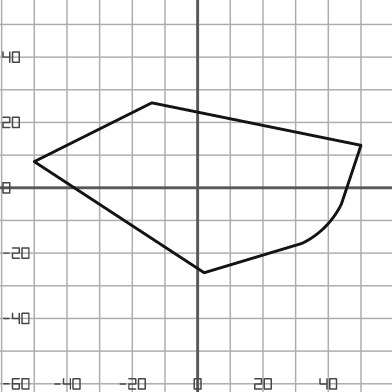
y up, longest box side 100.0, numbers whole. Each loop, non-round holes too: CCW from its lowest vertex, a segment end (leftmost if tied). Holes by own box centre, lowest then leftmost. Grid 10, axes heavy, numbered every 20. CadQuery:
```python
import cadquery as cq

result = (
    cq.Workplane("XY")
    .moveTo(2.0, -26.0)
    .lineTo(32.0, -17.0)
    .threePointArc((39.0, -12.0), (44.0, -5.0))
    .lineTo(50.0, 13.0)
    .lineTo(-14.0, 26.0)
    .lineTo(-50.0, 8.0)
    .close()
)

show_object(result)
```